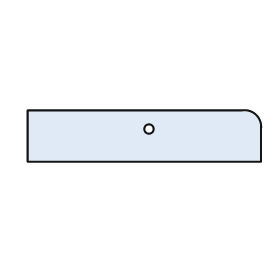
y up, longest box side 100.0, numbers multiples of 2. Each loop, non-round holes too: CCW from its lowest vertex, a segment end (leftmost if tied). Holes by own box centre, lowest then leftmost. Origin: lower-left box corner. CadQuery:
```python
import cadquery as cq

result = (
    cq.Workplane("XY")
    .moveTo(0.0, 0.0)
    .lineTo(100.0, 0.0)
    .lineTo(100.0, 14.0)
    .threePointArc((98.0, 20.0), (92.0, 22.0))
    .lineTo(0.0, 22.0)
    .close()
    .moveTo(52.0, 14.0)
    .circle(2.0)
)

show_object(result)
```